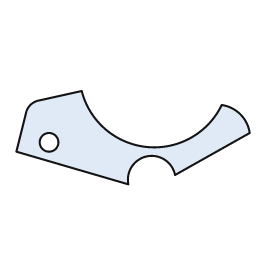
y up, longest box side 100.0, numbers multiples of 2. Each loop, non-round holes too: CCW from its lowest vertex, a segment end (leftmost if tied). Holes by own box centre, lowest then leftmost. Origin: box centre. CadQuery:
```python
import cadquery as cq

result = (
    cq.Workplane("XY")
    .moveTo(-2.0, -20.0)
    .threePointArc((6.0, -8.0), (18.0, -16.0))
    .lineTo(50.0, 2.0)
    .threePointArc((46.0, 10.0), (38.0, 14.0))
    .threePointArc((6.0, -4.0), (-22.0, 20.0))
    .lineTo(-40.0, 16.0)
    .threePointArc((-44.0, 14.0), (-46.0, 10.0))
    .lineTo(-50.0, -6.0)
    .close()
    .moveTo(-36.0, -2.0)
    .circle(4.0)
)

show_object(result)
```